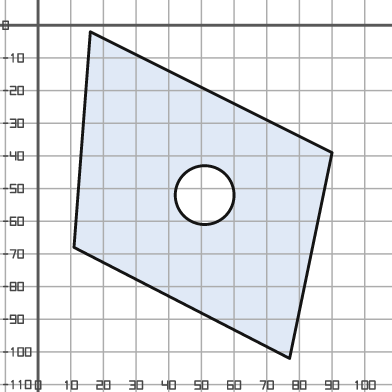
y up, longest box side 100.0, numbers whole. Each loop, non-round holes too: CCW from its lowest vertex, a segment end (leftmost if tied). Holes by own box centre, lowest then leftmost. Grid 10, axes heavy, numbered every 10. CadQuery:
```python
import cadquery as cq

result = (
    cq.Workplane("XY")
    .moveTo(77.0, -102.0)
    .lineTo(90.0, -39.0)
    .lineTo(16.0, -2.0)
    .lineTo(11.0, -68.0)
    .close()
    .moveTo(51.0, -52.0)
    .circle(9.0)
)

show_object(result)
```